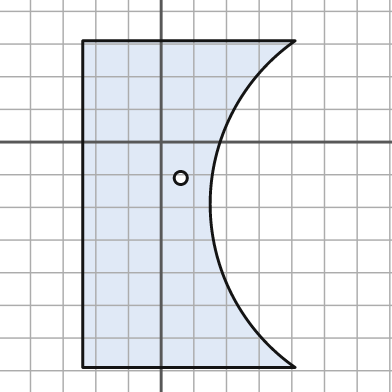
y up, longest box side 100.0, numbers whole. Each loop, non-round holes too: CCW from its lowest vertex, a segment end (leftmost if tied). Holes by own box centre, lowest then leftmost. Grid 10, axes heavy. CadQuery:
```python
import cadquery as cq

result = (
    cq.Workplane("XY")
    .moveTo(-24.0, -69.0)
    .lineTo(41.0, -69.0)
    .threePointArc((15.0, -19.0), (41.0, 31.0))
    .lineTo(-24.0, 31.0)
    .close()
    .moveTo(6.0, -11.0)
    .circle(2.0)
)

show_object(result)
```